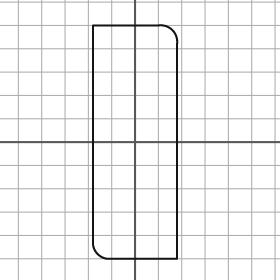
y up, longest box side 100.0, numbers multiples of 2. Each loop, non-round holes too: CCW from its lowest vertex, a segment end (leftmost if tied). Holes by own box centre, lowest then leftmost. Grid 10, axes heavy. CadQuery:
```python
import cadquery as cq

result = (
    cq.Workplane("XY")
    .moveTo(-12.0, -50.0)
    .lineTo(18.0, -50.0)
    .lineTo(18.0, 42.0)
    .threePointArc((16.0, 48.0), (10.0, 50.0))
    .lineTo(-18.0, 50.0)
    .lineTo(-18.0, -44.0)
    .threePointArc((-16.0, -48.0), (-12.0, -50.0))
    .close()
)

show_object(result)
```